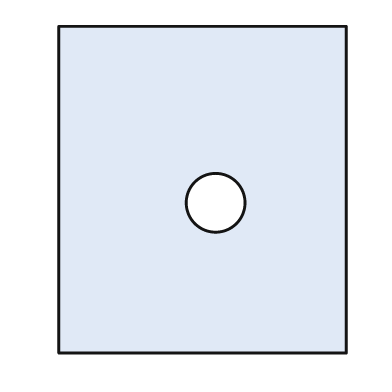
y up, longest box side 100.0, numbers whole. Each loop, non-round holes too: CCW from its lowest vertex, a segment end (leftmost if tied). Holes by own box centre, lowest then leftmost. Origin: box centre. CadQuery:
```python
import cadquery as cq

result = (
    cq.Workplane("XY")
    .moveTo(-44.0, -50.0)
    .lineTo(44.0, -50.0)
    .lineTo(44.0, 50.0)
    .lineTo(-44.0, 50.0)
    .close()
    .moveTo(4.0, -4.0)
    .circle(9.0)
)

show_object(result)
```